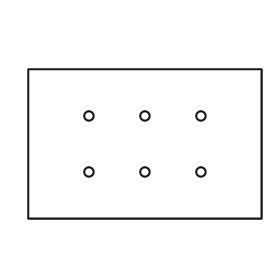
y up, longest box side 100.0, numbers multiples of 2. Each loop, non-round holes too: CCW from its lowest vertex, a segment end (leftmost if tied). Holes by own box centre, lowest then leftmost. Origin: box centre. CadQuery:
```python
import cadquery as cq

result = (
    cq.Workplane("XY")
    .moveTo(-50.0, -32.0)
    .lineTo(50.0, -32.0)
    .lineTo(50.0, 32.0)
    .lineTo(-50.0, 32.0)
    .close()
    .moveTo(-24.0, -12.0)
    .circle(2.0)
    .moveTo(0.0, -12.0)
    .circle(2.0)
    .moveTo(24.0, -12.0)
    .circle(2.0)
    .moveTo(-24.0, 12.0)
    .circle(2.0)
    .moveTo(0.0, 12.0)
    .circle(2.0)
    .moveTo(24.0, 12.0)
    .circle(2.0)
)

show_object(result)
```